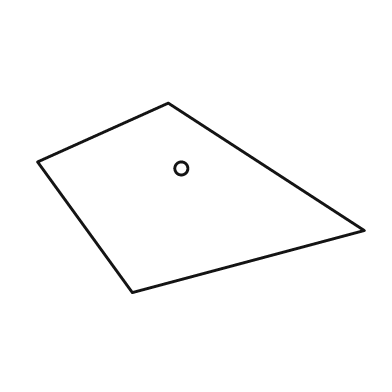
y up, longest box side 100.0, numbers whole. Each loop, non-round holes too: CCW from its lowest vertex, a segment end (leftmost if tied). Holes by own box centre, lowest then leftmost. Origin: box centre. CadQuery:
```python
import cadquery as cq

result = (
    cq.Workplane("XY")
    .moveTo(-21.0, -29.0)
    .lineTo(50.0, -10.0)
    .lineTo(-10.0, 29.0)
    .lineTo(-50.0, 11.0)
    .close()
    .moveTo(-6.0, 9.0)
    .circle(2.0)
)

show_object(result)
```